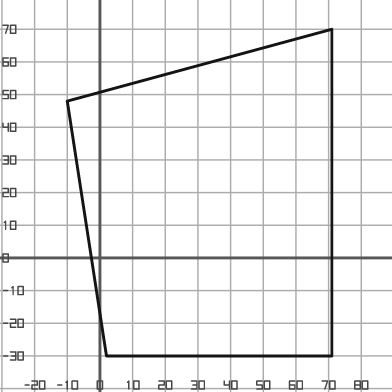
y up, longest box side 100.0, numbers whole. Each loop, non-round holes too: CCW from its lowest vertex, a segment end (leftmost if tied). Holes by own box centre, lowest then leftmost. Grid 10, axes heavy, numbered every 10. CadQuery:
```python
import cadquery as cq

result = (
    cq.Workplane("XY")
    .moveTo(2.0, -30.0)
    .lineTo(71.0, -30.0)
    .lineTo(71.0, 70.0)
    .lineTo(-10.0, 48.0)
    .close()
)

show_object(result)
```